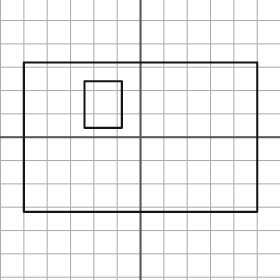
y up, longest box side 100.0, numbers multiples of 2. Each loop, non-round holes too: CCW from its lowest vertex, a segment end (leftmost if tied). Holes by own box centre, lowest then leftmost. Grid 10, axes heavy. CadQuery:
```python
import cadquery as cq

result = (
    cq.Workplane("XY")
    .moveTo(-50.0, -32.0)
    .lineTo(50.0, -32.0)
    .lineTo(50.0, 32.0)
    .lineTo(-50.0, 32.0)
    .close()
    .moveTo(-24.0, 4.0)
    .lineTo(-8.0, 4.0)
    .lineTo(-8.0, 24.0)
    .lineTo(-24.0, 24.0)
    .close()
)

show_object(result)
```